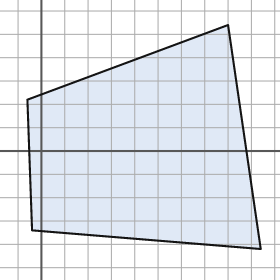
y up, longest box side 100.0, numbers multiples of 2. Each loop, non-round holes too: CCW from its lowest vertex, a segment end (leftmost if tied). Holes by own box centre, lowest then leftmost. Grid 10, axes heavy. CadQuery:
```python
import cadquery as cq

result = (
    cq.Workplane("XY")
    .moveTo(94.0, -42.0)
    .lineTo(80.0, 54.0)
    .lineTo(-6.0, 22.0)
    .lineTo(-4.0, -34.0)
    .close()
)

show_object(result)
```